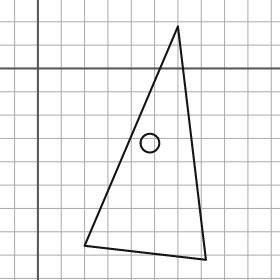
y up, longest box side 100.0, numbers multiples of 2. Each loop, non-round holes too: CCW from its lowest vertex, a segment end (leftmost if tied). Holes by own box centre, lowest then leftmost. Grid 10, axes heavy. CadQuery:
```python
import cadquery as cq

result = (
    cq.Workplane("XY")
    .moveTo(72.0, -82.0)
    .lineTo(60.0, 18.0)
    .lineTo(20.0, -76.0)
    .close()
    .moveTo(48.0, -32.0)
    .circle(4.0)
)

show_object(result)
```